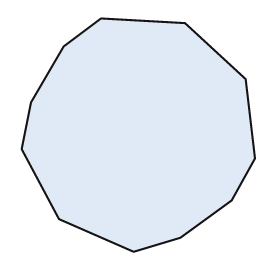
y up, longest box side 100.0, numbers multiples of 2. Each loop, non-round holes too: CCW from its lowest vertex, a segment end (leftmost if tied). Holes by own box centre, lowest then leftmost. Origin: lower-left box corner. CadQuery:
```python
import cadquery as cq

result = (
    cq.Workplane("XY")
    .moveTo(48.0, 0.0)
    .lineTo(68.0, 6.0)
    .lineTo(90.0, 22.0)
    .lineTo(100.0, 40.0)
    .lineTo(96.0, 74.0)
    .lineTo(70.0, 98.0)
    .lineTo(34.0, 100.0)
    .lineTo(18.0, 88.0)
    .lineTo(4.0, 64.0)
    .lineTo(0.0, 44.0)
    .lineTo(16.0, 14.0)
    .close()
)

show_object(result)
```